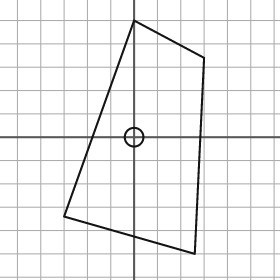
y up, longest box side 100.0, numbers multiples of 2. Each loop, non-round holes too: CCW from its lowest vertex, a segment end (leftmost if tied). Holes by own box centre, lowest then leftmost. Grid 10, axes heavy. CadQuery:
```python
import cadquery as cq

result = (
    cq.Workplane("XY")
    .moveTo(26.0, -50.0)
    .lineTo(30.0, 34.0)
    .lineTo(0.0, 50.0)
    .lineTo(-30.0, -34.0)
    .close()
    .moveTo(0.0, 0.0)
    .circle(4.0)
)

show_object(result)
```